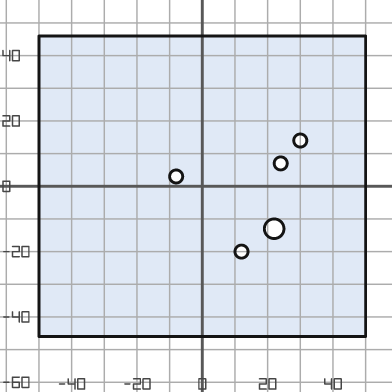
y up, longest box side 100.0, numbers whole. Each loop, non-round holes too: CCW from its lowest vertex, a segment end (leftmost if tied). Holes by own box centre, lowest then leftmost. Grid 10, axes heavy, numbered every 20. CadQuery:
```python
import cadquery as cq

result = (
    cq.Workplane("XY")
    .moveTo(-50.0, -46.0)
    .lineTo(50.0, -46.0)
    .lineTo(50.0, 46.0)
    .lineTo(-50.0, 46.0)
    .close()
    .moveTo(12.0, -20.0)
    .circle(2.0)
    .moveTo(22.0, -13.0)
    .circle(3.0)
    .moveTo(-8.0, 3.0)
    .circle(2.0)
    .moveTo(24.0, 7.0)
    .circle(2.0)
    .moveTo(30.0, 14.0)
    .circle(2.0)
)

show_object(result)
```